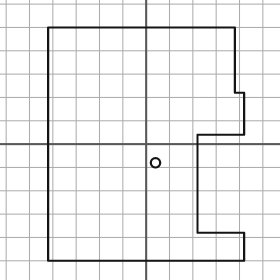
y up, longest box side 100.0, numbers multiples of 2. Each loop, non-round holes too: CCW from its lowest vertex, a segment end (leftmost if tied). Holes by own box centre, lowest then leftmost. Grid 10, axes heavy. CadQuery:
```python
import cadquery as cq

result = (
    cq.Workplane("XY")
    .moveTo(-42.0, -50.0)
    .lineTo(42.0, -50.0)
    .lineTo(42.0, -38.0)
    .lineTo(22.0, -38.0)
    .lineTo(22.0, 4.0)
    .lineTo(42.0, 4.0)
    .lineTo(42.0, 22.0)
    .lineTo(38.0, 22.0)
    .lineTo(38.0, 50.0)
    .lineTo(-42.0, 50.0)
    .close()
    .moveTo(4.0, -8.0)
    .circle(2.0)
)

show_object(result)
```